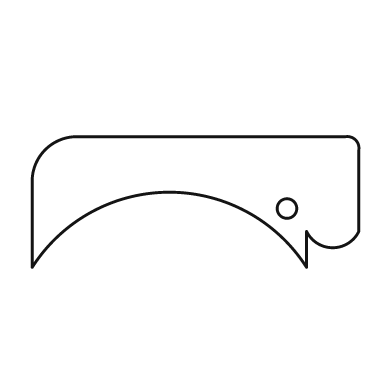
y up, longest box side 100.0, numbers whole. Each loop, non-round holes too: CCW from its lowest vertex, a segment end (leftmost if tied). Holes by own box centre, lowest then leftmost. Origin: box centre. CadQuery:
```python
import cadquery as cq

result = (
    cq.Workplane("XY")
    .moveTo(-50.0, -20.0)
    .threePointArc((-8.0, 3.0), (34.0, -20.0))
    .lineTo(34.0, -9.0)
    .threePointArc((42.0, -14.0), (50.0, -9.0))
    .lineTo(50.0, 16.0)
    .threePointArc((49.0, 19.0), (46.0, 20.0))
    .lineTo(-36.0, 20.0)
    .threePointArc((-46.0, 16.0), (-50.0, 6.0))
    .close()
    .moveTo(28.0, -2.0)
    .circle(3.0)
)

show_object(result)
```